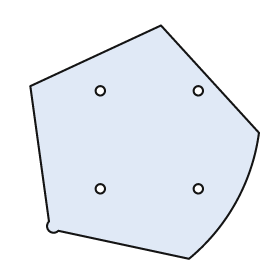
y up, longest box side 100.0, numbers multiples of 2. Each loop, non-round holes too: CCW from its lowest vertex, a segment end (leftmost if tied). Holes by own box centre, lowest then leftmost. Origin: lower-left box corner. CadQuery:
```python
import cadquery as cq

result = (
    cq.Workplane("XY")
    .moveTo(68.0, 0.0)
    .threePointArc((88.0, 24.0), (98.0, 54.0))
    .lineTo(56.0, 100.0)
    .lineTo(0.0, 74.0)
    .lineTo(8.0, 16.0)
    .threePointArc((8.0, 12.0), (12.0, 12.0))
    .close()
    .moveTo(30.0, 30.0)
    .circle(2.0)
    .moveTo(72.0, 30.0)
    .circle(2.0)
    .moveTo(30.0, 72.0)
    .circle(2.0)
    .moveTo(72.0, 72.0)
    .circle(2.0)
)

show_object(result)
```